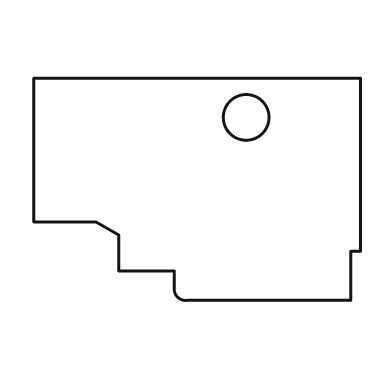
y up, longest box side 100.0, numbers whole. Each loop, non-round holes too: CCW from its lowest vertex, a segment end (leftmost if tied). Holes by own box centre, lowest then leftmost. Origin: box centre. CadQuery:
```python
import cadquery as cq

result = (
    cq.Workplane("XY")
    .moveTo(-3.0, -34.0)
    .lineTo(47.0, -34.0)
    .lineTo(47.0, -19.0)
    .lineTo(50.0, -19.0)
    .lineTo(50.0, 34.0)
    .lineTo(-50.0, 34.0)
    .lineTo(-50.0, -10.0)
    .lineTo(-31.0, -10.0)
    .lineTo(-24.0, -14.0)
    .lineTo(-24.0, -25.0)
    .lineTo(-7.0, -25.0)
    .lineTo(-7.0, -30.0)
    .threePointArc((-6.0, -33.0), (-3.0, -34.0))
    .close()
    .moveTo(15.0, 22.0)
    .circle(7.0)
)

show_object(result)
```